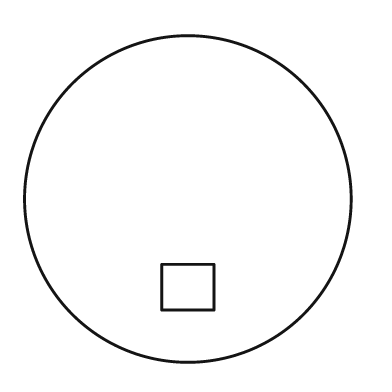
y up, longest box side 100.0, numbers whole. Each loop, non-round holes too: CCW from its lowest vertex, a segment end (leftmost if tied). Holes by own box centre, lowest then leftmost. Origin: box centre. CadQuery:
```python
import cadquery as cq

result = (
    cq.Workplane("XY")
    .moveTo(0.0, 0.0)
    .circle(50.0)
    .moveTo(-8.0, -34.0)
    .lineTo(8.0, -34.0)
    .lineTo(8.0, -20.0)
    .lineTo(-8.0, -20.0)
    .close()
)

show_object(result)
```